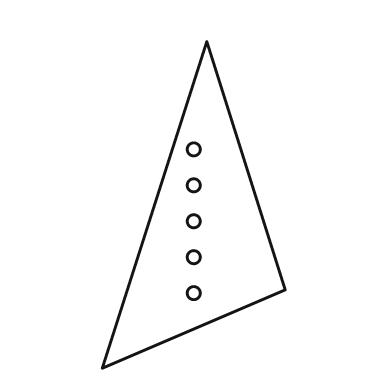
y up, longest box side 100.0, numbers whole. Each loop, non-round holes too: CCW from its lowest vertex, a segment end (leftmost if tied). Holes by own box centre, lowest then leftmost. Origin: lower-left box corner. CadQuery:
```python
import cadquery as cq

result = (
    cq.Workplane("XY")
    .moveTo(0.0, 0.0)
    .lineTo(56.0, 24.0)
    .lineTo(32.0, 100.0)
    .close()
    .moveTo(28.0, 23.0)
    .circle(2.0)
    .moveTo(28.0, 34.0)
    .circle(2.0)
    .moveTo(28.0, 45.0)
    .circle(2.0)
    .moveTo(28.0, 56.0)
    .circle(2.0)
    .moveTo(28.0, 67.0)
    .circle(2.0)
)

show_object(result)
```